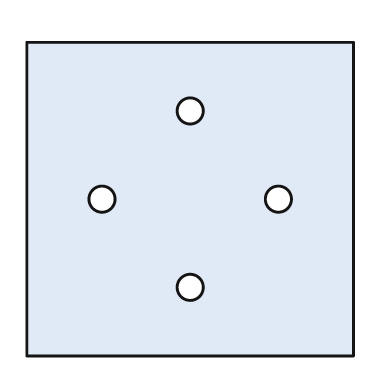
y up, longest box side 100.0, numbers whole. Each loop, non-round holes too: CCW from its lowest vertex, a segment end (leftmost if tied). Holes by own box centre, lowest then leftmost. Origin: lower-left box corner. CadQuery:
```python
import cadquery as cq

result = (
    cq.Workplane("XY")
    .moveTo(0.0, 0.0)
    .lineTo(100.0, 0.0)
    .lineTo(100.0, 96.0)
    .lineTo(0.0, 96.0)
    .close()
    .moveTo(50.0, 21.0)
    .circle(4.0)
    .moveTo(23.0, 48.0)
    .circle(4.0)
    .moveTo(77.0, 48.0)
    .circle(4.0)
    .moveTo(50.0, 75.0)
    .circle(4.0)
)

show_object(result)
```